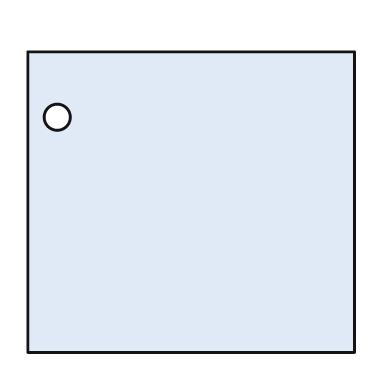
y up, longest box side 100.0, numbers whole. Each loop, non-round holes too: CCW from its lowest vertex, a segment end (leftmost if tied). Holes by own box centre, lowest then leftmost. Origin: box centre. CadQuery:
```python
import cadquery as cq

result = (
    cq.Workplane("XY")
    .moveTo(-50.0, -46.0)
    .lineTo(50.0, -46.0)
    .lineTo(50.0, 46.0)
    .lineTo(-50.0, 46.0)
    .close()
    .moveTo(-41.0, 26.0)
    .circle(4.0)
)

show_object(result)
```